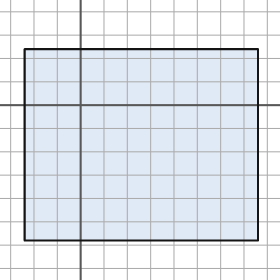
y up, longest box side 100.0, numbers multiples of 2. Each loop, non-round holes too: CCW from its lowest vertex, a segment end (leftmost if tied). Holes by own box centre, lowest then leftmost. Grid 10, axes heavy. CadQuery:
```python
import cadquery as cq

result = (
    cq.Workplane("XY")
    .moveTo(-24.0, -58.0)
    .lineTo(76.0, -58.0)
    .lineTo(76.0, 24.0)
    .lineTo(-24.0, 24.0)
    .close()
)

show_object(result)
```